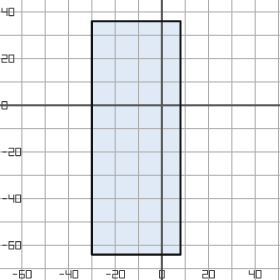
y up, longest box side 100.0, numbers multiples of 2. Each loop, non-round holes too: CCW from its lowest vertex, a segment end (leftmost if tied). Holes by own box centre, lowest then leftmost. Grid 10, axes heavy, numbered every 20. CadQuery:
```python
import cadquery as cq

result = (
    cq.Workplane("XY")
    .moveTo(-30.0, -64.0)
    .lineTo(8.0, -64.0)
    .lineTo(8.0, 36.0)
    .lineTo(-30.0, 36.0)
    .close()
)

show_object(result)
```